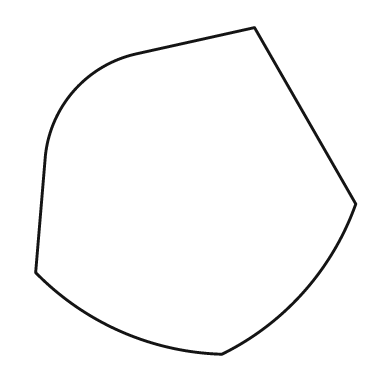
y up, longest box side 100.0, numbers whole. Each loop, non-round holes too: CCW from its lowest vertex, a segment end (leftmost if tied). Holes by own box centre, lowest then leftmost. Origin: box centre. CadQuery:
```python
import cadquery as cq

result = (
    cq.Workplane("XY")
    .moveTo(8.0, -50.0)
    .threePointArc((33.0, -31.0), (49.0, -4.0))
    .lineTo(18.0, 50.0)
    .lineTo(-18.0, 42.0)
    .threePointArc((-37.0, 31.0), (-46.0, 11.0))
    .lineTo(-49.0, -25.0)
    .threePointArc((-23.0, -43.0), (8.0, -50.0))
    .close()
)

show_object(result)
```